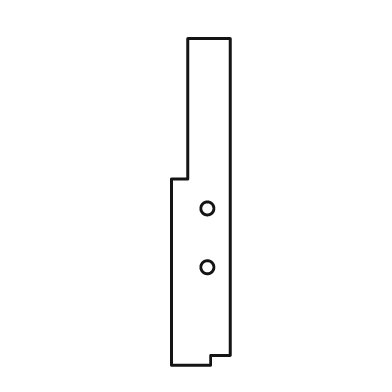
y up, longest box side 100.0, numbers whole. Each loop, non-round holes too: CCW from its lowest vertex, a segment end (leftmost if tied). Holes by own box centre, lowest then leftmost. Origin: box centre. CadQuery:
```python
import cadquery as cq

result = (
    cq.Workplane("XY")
    .moveTo(-9.0, -50.0)
    .lineTo(3.0, -50.0)
    .lineTo(3.0, -47.0)
    .lineTo(9.0, -47.0)
    .lineTo(9.0, 50.0)
    .lineTo(-4.0, 50.0)
    .lineTo(-4.0, 7.0)
    .lineTo(-9.0, 7.0)
    .close()
    .moveTo(2.0, -20.0)
    .circle(2.0)
    .moveTo(2.0, -2.0)
    .circle(2.0)
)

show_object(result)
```